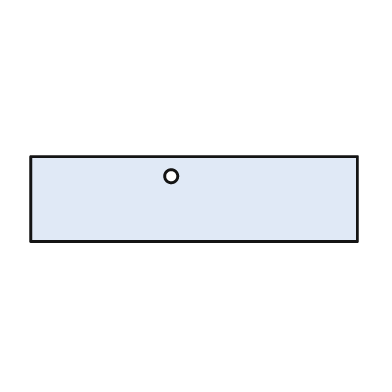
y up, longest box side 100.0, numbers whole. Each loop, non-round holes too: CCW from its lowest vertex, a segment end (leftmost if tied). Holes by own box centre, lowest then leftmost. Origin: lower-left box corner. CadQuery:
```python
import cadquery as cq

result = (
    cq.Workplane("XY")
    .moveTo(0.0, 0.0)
    .lineTo(100.0, 0.0)
    .lineTo(100.0, 26.0)
    .lineTo(0.0, 26.0)
    .close()
    .moveTo(43.0, 20.0)
    .circle(2.0)
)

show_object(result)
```